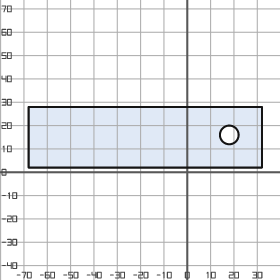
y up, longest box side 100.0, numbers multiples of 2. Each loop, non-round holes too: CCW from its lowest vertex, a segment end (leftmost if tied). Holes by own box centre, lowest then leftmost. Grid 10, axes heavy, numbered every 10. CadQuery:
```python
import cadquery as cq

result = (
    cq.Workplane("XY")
    .moveTo(-68.0, 2.0)
    .lineTo(32.0, 2.0)
    .lineTo(32.0, 28.0)
    .lineTo(-68.0, 28.0)
    .close()
    .moveTo(18.0, 16.0)
    .circle(4.0)
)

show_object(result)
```